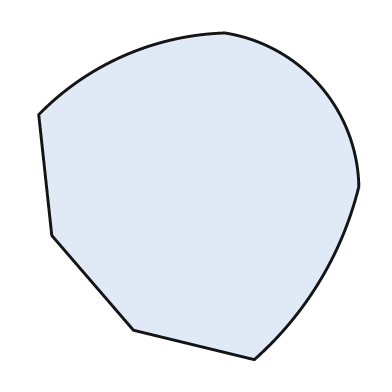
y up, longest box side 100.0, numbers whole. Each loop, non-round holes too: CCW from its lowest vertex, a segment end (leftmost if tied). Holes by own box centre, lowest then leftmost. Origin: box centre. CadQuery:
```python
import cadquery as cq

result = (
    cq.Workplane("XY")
    .moveTo(17.0, -50.0)
    .threePointArc((37.0, -26.0), (49.0, 3.0))
    .threePointArc((37.0, 34.0), (8.0, 50.0))
    .threePointArc((-23.0, 43.0), (-49.0, 25.0))
    .lineTo(-45.0, -12.0)
    .lineTo(-20.0, -41.0)
    .close()
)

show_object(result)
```